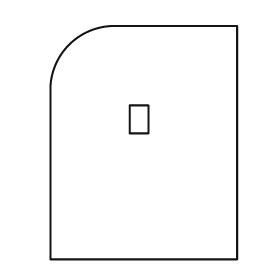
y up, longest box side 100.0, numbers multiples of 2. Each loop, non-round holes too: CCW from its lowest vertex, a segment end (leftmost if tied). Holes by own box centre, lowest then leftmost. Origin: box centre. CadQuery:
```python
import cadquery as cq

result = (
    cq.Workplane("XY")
    .moveTo(-40.0, -50.0)
    .lineTo(40.0, -50.0)
    .lineTo(40.0, 50.0)
    .lineTo(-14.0, 50.0)
    .threePointArc((-32.0, 42.0), (-40.0, 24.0))
    .close()
    .moveTo(-6.0, 4.0)
    .lineTo(2.0, 4.0)
    .lineTo(2.0, 16.0)
    .lineTo(-6.0, 16.0)
    .close()
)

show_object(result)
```